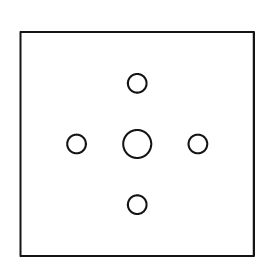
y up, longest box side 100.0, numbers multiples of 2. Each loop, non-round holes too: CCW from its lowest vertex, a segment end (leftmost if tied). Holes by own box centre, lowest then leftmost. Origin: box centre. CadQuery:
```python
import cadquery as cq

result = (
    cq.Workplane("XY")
    .moveTo(-50.0, -48.0)
    .lineTo(50.0, -48.0)
    .lineTo(50.0, 48.0)
    .lineTo(-50.0, 48.0)
    .close()
    .moveTo(0.0, -26.0)
    .circle(4.0)
    .moveTo(-26.0, 0.0)
    .circle(4.0)
    .moveTo(0.0, 0.0)
    .circle(6.0)
    .moveTo(26.0, 0.0)
    .circle(4.0)
    .moveTo(0.0, 26.0)
    .circle(4.0)
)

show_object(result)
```